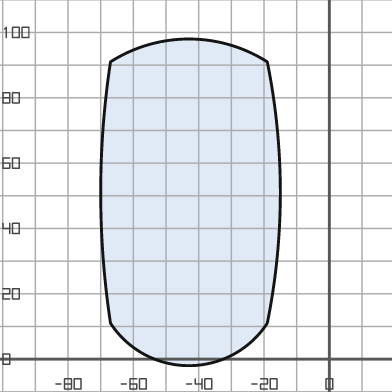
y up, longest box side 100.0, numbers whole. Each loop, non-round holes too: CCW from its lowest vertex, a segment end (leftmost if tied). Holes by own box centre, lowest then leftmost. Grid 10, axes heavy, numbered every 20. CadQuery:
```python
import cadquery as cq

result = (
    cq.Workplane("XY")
    .moveTo(-67.0, 11.0)
    .threePointArc((-43.0, -2.0), (-19.0, 11.0))
    .threePointArc((-15.0, 51.0), (-19.0, 91.0))
    .threePointArc((-43.0, 98.0), (-67.0, 91.0))
    .threePointArc((-70.0, 51.0), (-67.0, 11.0))
    .close()
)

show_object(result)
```